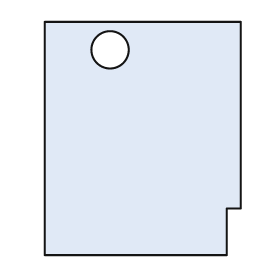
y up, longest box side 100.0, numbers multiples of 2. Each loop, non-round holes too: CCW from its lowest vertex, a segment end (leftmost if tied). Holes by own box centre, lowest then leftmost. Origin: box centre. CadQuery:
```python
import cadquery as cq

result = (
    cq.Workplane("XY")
    .moveTo(-42.0, -50.0)
    .lineTo(36.0, -50.0)
    .lineTo(36.0, -30.0)
    .lineTo(42.0, -30.0)
    .lineTo(42.0, 50.0)
    .lineTo(-42.0, 50.0)
    .close()
    .moveTo(-14.0, 38.0)
    .circle(8.0)
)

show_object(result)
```